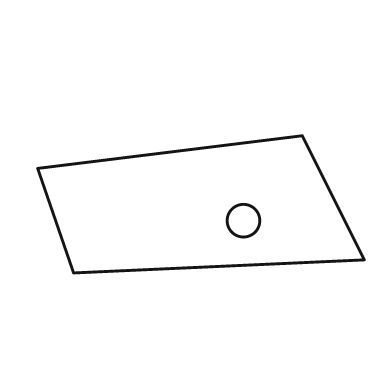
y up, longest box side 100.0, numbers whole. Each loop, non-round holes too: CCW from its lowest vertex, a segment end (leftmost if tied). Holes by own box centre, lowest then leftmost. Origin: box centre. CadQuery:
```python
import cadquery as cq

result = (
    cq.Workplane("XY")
    .moveTo(-39.0, -21.0)
    .lineTo(50.0, -17.0)
    .lineTo(31.0, 21.0)
    .lineTo(-50.0, 11.0)
    .close()
    .moveTo(13.0, -5.0)
    .circle(5.0)
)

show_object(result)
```